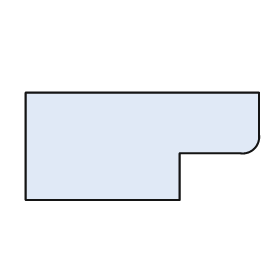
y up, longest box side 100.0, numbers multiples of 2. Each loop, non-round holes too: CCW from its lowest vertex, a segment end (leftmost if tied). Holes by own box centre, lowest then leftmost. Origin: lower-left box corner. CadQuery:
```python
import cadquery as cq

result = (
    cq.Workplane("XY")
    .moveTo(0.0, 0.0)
    .lineTo(66.0, 0.0)
    .lineTo(66.0, 20.0)
    .lineTo(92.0, 20.0)
    .threePointArc((98.0, 22.0), (100.0, 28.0))
    .lineTo(100.0, 46.0)
    .lineTo(0.0, 46.0)
    .close()
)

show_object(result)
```